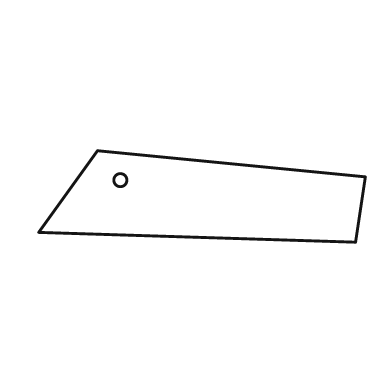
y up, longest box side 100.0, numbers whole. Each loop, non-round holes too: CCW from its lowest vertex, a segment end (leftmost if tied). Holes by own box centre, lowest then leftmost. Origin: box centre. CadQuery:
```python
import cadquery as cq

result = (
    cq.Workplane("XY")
    .moveTo(47.0, -14.0)
    .lineTo(50.0, 6.0)
    .lineTo(-32.0, 14.0)
    .lineTo(-50.0, -11.0)
    .close()
    .moveTo(-25.0, 5.0)
    .circle(2.0)
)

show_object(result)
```